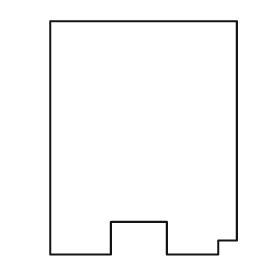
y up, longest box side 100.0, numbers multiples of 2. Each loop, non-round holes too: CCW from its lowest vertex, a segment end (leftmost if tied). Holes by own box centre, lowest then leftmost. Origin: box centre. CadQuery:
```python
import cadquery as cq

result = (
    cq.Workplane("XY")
    .moveTo(-40.0, -50.0)
    .lineTo(-14.0, -50.0)
    .lineTo(-14.0, -36.0)
    .lineTo(10.0, -36.0)
    .lineTo(10.0, -50.0)
    .lineTo(32.0, -50.0)
    .lineTo(32.0, -44.0)
    .lineTo(40.0, -44.0)
    .lineTo(40.0, 50.0)
    .lineTo(-40.0, 50.0)
    .close()
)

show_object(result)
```